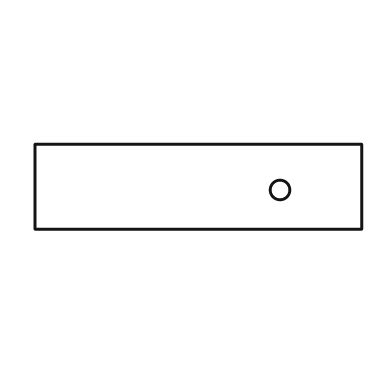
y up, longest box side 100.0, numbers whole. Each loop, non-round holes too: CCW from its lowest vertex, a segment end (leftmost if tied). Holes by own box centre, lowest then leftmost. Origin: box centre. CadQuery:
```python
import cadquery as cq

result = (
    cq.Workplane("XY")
    .moveTo(-50.0, -13.0)
    .lineTo(50.0, -13.0)
    .lineTo(50.0, 13.0)
    .lineTo(-50.0, 13.0)
    .close()
    .moveTo(25.0, -1.0)
    .circle(3.0)
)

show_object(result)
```